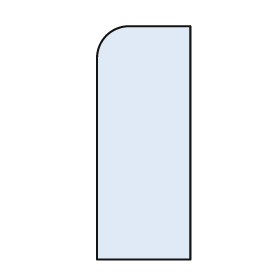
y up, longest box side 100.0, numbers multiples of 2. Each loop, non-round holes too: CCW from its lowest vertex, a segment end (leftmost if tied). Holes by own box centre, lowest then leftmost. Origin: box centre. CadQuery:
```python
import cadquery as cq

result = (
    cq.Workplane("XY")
    .moveTo(-20.0, -50.0)
    .lineTo(20.0, -50.0)
    .lineTo(20.0, 50.0)
    .lineTo(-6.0, 50.0)
    .threePointArc((-16.0, 46.0), (-20.0, 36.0))
    .close()
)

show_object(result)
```